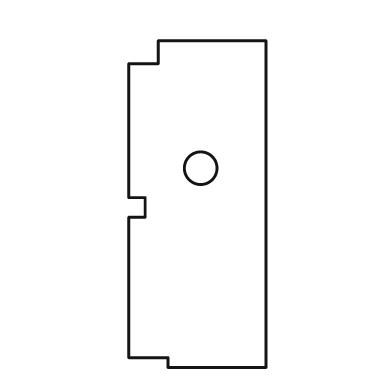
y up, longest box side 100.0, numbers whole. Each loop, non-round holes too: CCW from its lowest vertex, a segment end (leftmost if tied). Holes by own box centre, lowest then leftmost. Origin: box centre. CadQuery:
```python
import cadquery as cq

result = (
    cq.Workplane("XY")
    .moveTo(-9.0, -50.0)
    .lineTo(21.0, -50.0)
    .lineTo(21.0, 50.0)
    .lineTo(-12.0, 50.0)
    .lineTo(-12.0, 43.0)
    .lineTo(-21.0, 43.0)
    .lineTo(-21.0, 2.0)
    .lineTo(-16.0, 2.0)
    .lineTo(-16.0, -4.0)
    .lineTo(-21.0, -4.0)
    .lineTo(-21.0, -47.0)
    .lineTo(-9.0, -47.0)
    .close()
    .moveTo(1.0, 11.0)
    .circle(5.0)
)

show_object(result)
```